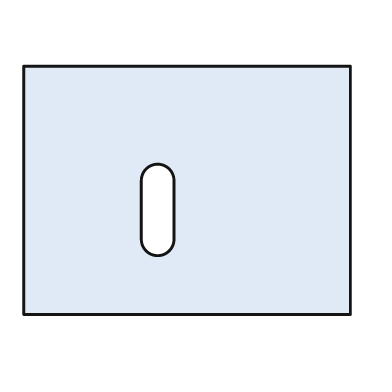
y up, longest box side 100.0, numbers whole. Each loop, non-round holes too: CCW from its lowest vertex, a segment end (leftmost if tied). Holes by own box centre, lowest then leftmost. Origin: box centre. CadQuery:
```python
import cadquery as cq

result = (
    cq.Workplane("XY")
    .moveTo(-50.0, -38.0)
    .lineTo(50.0, -38.0)
    .lineTo(50.0, 38.0)
    .lineTo(-50.0, 38.0)
    .close()
    .moveTo(-14.0, -15.0)
    .threePointArc((-9.0, -20.0), (-4.0, -15.0))
    .lineTo(-4.0, 3.0)
    .threePointArc((-9.0, 8.0), (-14.0, 3.0))
    .close()
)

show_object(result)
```